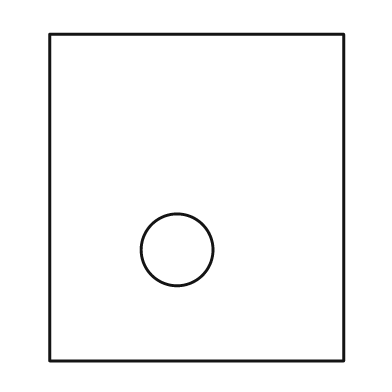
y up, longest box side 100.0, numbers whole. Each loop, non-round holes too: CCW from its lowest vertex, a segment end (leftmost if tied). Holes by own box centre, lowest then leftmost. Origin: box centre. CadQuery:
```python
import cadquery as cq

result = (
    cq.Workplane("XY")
    .moveTo(-45.0, -50.0)
    .lineTo(45.0, -50.0)
    .lineTo(45.0, 50.0)
    .lineTo(-45.0, 50.0)
    .close()
    .moveTo(-6.0, -16.0)
    .circle(11.0)
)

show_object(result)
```